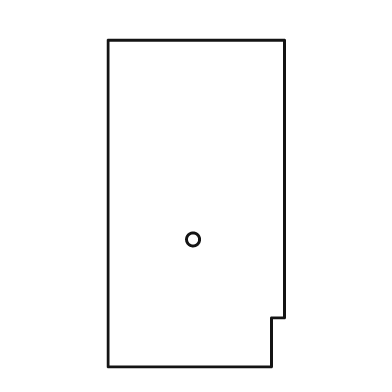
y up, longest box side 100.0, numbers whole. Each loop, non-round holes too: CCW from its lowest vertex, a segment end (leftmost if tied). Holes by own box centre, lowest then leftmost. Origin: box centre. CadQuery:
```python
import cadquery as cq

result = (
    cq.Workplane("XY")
    .moveTo(-27.0, -50.0)
    .lineTo(23.0, -50.0)
    .lineTo(23.0, -35.0)
    .lineTo(27.0, -35.0)
    .lineTo(27.0, 50.0)
    .lineTo(-27.0, 50.0)
    .close()
    .moveTo(-1.0, -11.0)
    .circle(2.0)
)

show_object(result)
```